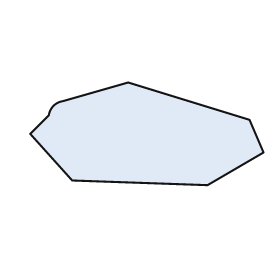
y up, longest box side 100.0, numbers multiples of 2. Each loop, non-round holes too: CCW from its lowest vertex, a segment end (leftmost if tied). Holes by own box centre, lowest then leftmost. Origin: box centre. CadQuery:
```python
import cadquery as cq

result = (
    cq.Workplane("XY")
    .moveTo(26.0, -22.0)
    .lineTo(50.0, -8.0)
    .lineTo(44.0, 6.0)
    .lineTo(-8.0, 22.0)
    .lineTo(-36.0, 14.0)
    .threePointArc((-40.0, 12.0), (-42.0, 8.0))
    .lineTo(-50.0, 0.0)
    .lineTo(-32.0, -20.0)
    .close()
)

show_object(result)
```